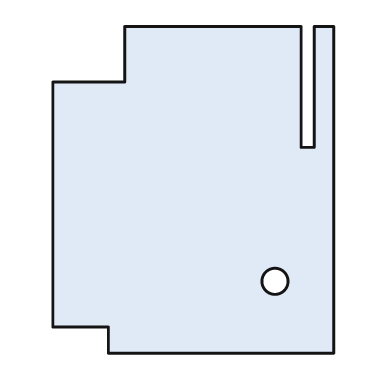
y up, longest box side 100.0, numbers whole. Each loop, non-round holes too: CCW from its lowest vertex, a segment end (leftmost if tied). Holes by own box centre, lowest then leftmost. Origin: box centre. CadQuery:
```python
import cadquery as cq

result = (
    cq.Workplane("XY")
    .moveTo(-26.0, -50.0)
    .lineTo(43.0, -50.0)
    .lineTo(43.0, 50.0)
    .lineTo(37.0, 50.0)
    .lineTo(37.0, 13.0)
    .lineTo(33.0, 13.0)
    .lineTo(33.0, 50.0)
    .lineTo(-21.0, 50.0)
    .lineTo(-21.0, 33.0)
    .lineTo(-43.0, 33.0)
    .lineTo(-43.0, -42.0)
    .lineTo(-26.0, -42.0)
    .close()
    .moveTo(25.0, -28.0)
    .circle(4.0)
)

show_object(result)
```